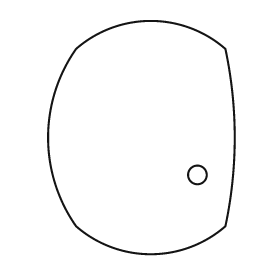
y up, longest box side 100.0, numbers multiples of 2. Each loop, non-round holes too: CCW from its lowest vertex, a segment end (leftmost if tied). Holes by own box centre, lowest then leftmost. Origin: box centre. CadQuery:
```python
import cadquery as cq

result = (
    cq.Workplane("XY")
    .moveTo(-28.0, -38.0)
    .threePointArc((4.0, -50.0), (36.0, -38.0))
    .threePointArc((40.0, 0.0), (36.0, 38.0))
    .threePointArc((4.0, 50.0), (-28.0, 38.0))
    .threePointArc((-40.0, 0.0), (-28.0, -38.0))
    .close()
    .moveTo(24.0, -16.0)
    .circle(4.0)
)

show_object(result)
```